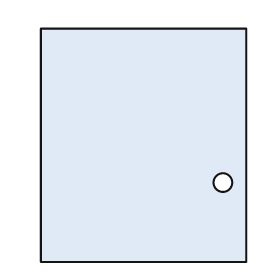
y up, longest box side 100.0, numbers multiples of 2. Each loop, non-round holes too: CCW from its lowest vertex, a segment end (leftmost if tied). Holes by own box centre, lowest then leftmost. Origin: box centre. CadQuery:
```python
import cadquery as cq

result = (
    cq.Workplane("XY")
    .moveTo(-44.0, -50.0)
    .lineTo(44.0, -50.0)
    .lineTo(44.0, 50.0)
    .lineTo(-44.0, 50.0)
    .close()
    .moveTo(34.0, -16.0)
    .circle(4.0)
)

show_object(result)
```